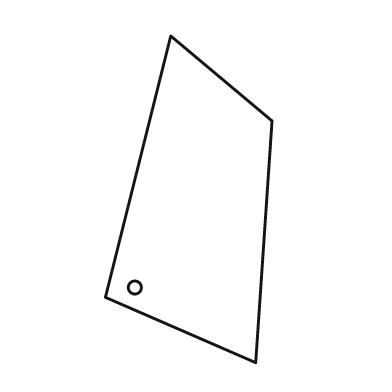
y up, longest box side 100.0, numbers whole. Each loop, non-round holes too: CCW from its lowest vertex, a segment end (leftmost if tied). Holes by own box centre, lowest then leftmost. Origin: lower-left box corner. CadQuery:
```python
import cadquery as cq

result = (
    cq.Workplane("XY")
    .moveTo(46.0, 0.0)
    .lineTo(51.0, 74.0)
    .lineTo(20.0, 100.0)
    .lineTo(0.0, 20.0)
    .close()
    .moveTo(9.0, 23.0)
    .circle(2.0)
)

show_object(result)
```